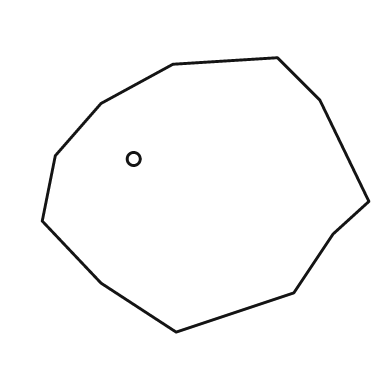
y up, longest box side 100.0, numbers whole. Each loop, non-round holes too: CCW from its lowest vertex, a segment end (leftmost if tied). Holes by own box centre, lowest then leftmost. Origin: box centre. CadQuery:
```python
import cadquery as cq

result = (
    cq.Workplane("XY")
    .moveTo(-9.0, -42.0)
    .lineTo(27.0, -30.0)
    .lineTo(39.0, -12.0)
    .lineTo(50.0, -2.0)
    .lineTo(35.0, 29.0)
    .lineTo(22.0, 42.0)
    .lineTo(-10.0, 40.0)
    .lineTo(-32.0, 28.0)
    .lineTo(-46.0, 12.0)
    .lineTo(-50.0, -8.0)
    .lineTo(-32.0, -27.0)
    .close()
    .moveTo(-22.0, 11.0)
    .circle(2.0)
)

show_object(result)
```